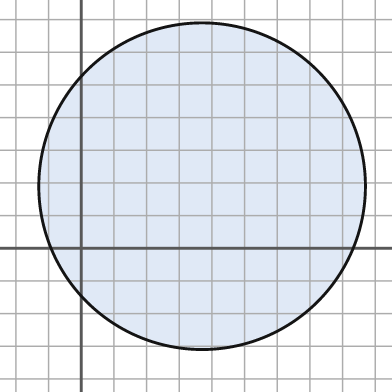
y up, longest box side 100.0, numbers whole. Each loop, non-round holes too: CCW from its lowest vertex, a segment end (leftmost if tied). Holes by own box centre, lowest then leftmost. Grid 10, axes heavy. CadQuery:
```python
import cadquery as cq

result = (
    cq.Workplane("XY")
    .moveTo(37.0, 19.0)
    .circle(50.0)
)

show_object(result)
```